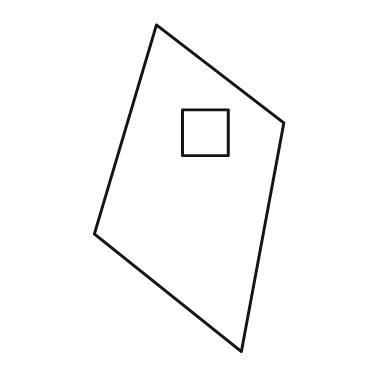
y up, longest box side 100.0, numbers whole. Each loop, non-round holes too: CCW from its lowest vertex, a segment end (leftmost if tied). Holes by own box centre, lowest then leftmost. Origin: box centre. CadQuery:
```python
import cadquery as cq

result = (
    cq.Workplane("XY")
    .moveTo(16.0, -50.0)
    .lineTo(29.0, 20.0)
    .lineTo(-10.0, 50.0)
    .lineTo(-29.0, -14.0)
    .close()
    .moveTo(-2.0, 10.0)
    .lineTo(12.0, 10.0)
    .lineTo(12.0, 24.0)
    .lineTo(-2.0, 24.0)
    .close()
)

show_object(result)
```